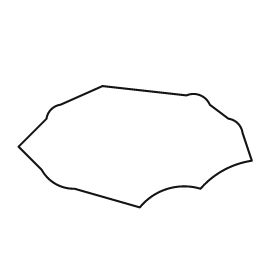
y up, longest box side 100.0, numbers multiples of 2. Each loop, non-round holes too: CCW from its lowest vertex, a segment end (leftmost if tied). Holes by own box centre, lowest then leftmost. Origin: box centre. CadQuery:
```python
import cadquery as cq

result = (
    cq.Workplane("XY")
    .moveTo(2.0, -26.0)
    .threePointArc((14.0, -18.0), (28.0, -18.0))
    .threePointArc((38.0, -10.0), (50.0, -6.0))
    .lineTo(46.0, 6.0)
    .threePointArc((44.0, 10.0), (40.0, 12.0))
    .lineTo(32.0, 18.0)
    .threePointArc((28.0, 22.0), (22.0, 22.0))
    .lineTo(-14.0, 26.0)
    .lineTo(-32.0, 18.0)
    .threePointArc((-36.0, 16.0), (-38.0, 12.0))
    .lineTo(-50.0, 0.0)
    .lineTo(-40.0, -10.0)
    .threePointArc((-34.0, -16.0), (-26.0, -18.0))
    .close()
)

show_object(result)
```